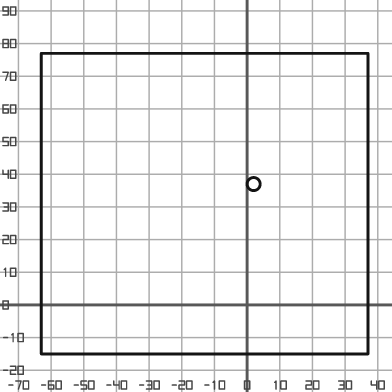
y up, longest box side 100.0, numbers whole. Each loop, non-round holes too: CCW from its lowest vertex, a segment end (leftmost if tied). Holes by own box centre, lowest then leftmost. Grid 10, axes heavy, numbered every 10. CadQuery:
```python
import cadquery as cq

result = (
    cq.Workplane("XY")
    .moveTo(-63.0, -15.0)
    .lineTo(37.0, -15.0)
    .lineTo(37.0, 77.0)
    .lineTo(-63.0, 77.0)
    .close()
    .moveTo(2.0, 37.0)
    .circle(2.0)
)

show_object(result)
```